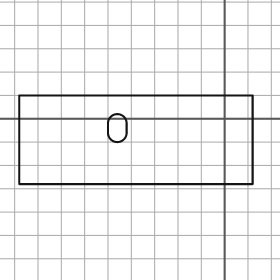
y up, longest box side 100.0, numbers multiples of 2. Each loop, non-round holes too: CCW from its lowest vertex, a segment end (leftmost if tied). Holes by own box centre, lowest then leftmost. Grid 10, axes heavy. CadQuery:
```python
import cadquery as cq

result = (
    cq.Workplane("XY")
    .moveTo(-88.0, -28.0)
    .lineTo(12.0, -28.0)
    .lineTo(12.0, 10.0)
    .lineTo(-88.0, 10.0)
    .close()
    .moveTo(-50.0, -6.0)
    .threePointArc((-46.0, -10.0), (-42.0, -6.0))
    .lineTo(-42.0, -2.0)
    .threePointArc((-46.0, 2.0), (-50.0, -2.0))
    .close()
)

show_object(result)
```